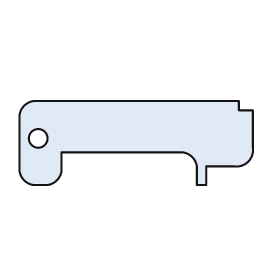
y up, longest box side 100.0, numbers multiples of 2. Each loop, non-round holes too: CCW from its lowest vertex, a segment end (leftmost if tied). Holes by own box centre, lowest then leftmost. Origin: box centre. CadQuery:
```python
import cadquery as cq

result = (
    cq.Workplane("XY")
    .moveTo(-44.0, -18.0)
    .lineTo(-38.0, -18.0)
    .threePointArc((-34.0, -16.0), (-32.0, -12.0))
    .lineTo(-32.0, -4.0)
    .lineTo(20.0, -4.0)
    .threePointArc((24.0, -6.0), (26.0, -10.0))
    .lineTo(26.0, -18.0)
    .lineTo(30.0, -18.0)
    .lineTo(30.0, -10.0)
    .lineTo(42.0, -10.0)
    .threePointArc((48.0, -8.0), (50.0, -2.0))
    .lineTo(50.0, 14.0)
    .lineTo(44.0, 14.0)
    .lineTo(44.0, 18.0)
    .lineTo(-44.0, 18.0)
    .threePointArc((-48.0, 16.0), (-50.0, 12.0))
    .lineTo(-50.0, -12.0)
    .threePointArc((-48.0, -16.0), (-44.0, -18.0))
    .close()
    .moveTo(-42.0, 2.0)
    .circle(4.0)
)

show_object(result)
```